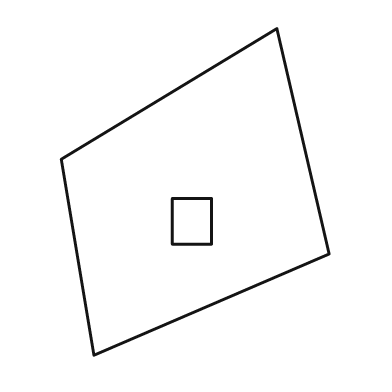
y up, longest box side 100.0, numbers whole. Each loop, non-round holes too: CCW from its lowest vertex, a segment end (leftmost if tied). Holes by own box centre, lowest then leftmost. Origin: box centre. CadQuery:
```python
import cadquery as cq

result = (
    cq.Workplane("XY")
    .moveTo(-31.0, -50.0)
    .lineTo(41.0, -19.0)
    .lineTo(25.0, 50.0)
    .lineTo(-41.0, 10.0)
    .close()
    .moveTo(-7.0, -16.0)
    .lineTo(5.0, -16.0)
    .lineTo(5.0, -2.0)
    .lineTo(-7.0, -2.0)
    .close()
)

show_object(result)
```